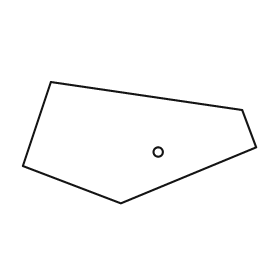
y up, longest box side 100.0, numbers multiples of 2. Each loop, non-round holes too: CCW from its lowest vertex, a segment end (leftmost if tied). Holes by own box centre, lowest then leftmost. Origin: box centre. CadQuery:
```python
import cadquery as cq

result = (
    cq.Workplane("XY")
    .moveTo(-8.0, -26.0)
    .lineTo(50.0, -2.0)
    .lineTo(44.0, 14.0)
    .lineTo(-38.0, 26.0)
    .lineTo(-50.0, -10.0)
    .close()
    .moveTo(8.0, -4.0)
    .circle(2.0)
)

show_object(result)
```